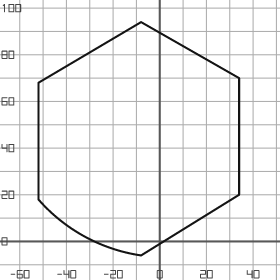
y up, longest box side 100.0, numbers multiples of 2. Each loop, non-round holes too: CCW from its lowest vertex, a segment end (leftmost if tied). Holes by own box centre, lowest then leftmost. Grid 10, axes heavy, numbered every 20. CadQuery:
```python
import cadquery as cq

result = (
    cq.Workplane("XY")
    .moveTo(-8.0, -6.0)
    .lineTo(34.0, 20.0)
    .lineTo(34.0, 70.0)
    .lineTo(-8.0, 94.0)
    .lineTo(-52.0, 68.0)
    .lineTo(-52.0, 18.0)
    .threePointArc((-32.0, 2.0), (-8.0, -6.0))
    .close()
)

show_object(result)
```